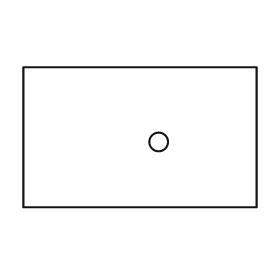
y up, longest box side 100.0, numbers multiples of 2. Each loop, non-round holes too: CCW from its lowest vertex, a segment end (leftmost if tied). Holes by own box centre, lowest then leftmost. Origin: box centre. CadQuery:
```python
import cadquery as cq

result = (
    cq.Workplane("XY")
    .moveTo(-50.0, -30.0)
    .lineTo(50.0, -30.0)
    .lineTo(50.0, 30.0)
    .lineTo(-50.0, 30.0)
    .close()
    .moveTo(8.0, -2.0)
    .circle(4.0)
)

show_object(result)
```